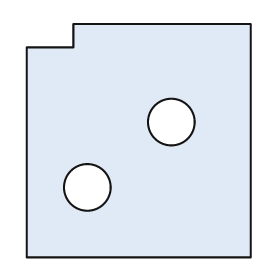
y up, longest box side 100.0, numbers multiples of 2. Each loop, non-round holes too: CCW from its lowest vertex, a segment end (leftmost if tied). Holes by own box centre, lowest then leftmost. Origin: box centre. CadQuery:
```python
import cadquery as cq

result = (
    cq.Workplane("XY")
    .moveTo(-48.0, -50.0)
    .lineTo(48.0, -50.0)
    .lineTo(48.0, 50.0)
    .lineTo(-28.0, 50.0)
    .lineTo(-28.0, 40.0)
    .lineTo(-48.0, 40.0)
    .close()
    .moveTo(-22.0, -20.0)
    .circle(10.0)
    .moveTo(14.0, 8.0)
    .circle(10.0)
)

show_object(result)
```